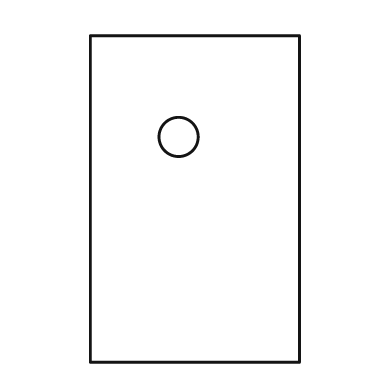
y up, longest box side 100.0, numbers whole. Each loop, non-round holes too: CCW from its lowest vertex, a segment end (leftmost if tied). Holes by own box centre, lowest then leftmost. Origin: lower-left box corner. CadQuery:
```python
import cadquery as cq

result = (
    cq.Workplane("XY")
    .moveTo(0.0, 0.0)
    .lineTo(64.0, 0.0)
    .lineTo(64.0, 100.0)
    .lineTo(0.0, 100.0)
    .close()
    .moveTo(27.0, 69.0)
    .circle(6.0)
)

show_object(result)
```